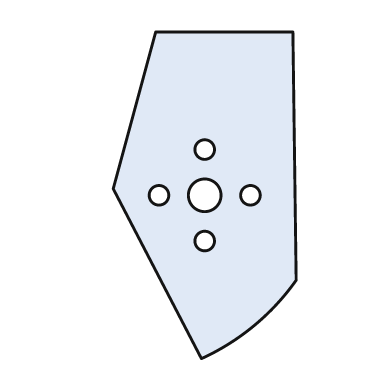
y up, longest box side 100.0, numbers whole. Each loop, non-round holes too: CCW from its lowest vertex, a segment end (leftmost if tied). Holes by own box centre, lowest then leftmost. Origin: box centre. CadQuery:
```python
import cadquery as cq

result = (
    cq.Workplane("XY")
    .moveTo(-1.0, -50.0)
    .threePointArc((15.0, -40.0), (28.0, -26.0))
    .lineTo(27.0, 50.0)
    .lineTo(-15.0, 50.0)
    .lineTo(-28.0, 2.0)
    .close()
    .moveTo(0.0, -14.0)
    .circle(3.0)
    .moveTo(-14.0, 0.0)
    .circle(3.0)
    .moveTo(0.0, 0.0)
    .circle(5.0)
    .moveTo(14.0, 0.0)
    .circle(3.0)
    .moveTo(0.0, 14.0)
    .circle(3.0)
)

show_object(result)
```